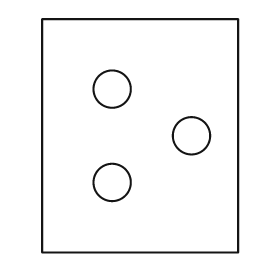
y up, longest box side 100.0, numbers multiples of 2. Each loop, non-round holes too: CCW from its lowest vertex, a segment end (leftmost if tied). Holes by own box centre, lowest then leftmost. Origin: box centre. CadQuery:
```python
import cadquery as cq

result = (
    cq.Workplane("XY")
    .moveTo(-42.0, -50.0)
    .lineTo(42.0, -50.0)
    .lineTo(42.0, 50.0)
    .lineTo(-42.0, 50.0)
    .close()
    .moveTo(-12.0, -20.0)
    .circle(8.0)
    .moveTo(22.0, 0.0)
    .circle(8.0)
    .moveTo(-12.0, 20.0)
    .circle(8.0)
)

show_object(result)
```